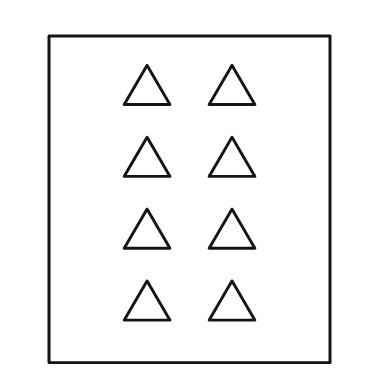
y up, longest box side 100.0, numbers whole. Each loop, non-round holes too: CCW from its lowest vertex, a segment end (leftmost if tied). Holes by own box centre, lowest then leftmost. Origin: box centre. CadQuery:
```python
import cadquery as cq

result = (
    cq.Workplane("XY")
    .moveTo(-43.0, -50.0)
    .lineTo(43.0, -50.0)
    .lineTo(43.0, 50.0)
    .lineTo(-43.0, 50.0)
    .close()
    .moveTo(-20.0, -37.0)
    .lineTo(-6.0, -37.0)
    .lineTo(-13.0, -25.0)
    .close()
    .moveTo(6.0, -37.0)
    .lineTo(20.0, -37.0)
    .lineTo(13.0, -25.0)
    .close()
    .moveTo(-20.0, -15.0)
    .lineTo(-6.0, -15.0)
    .lineTo(-13.0, -3.0)
    .close()
    .moveTo(6.0, -15.0)
    .lineTo(20.0, -15.0)
    .lineTo(13.0, -3.0)
    .close()
    .moveTo(-20.0, 7.0)
    .lineTo(-6.0, 7.0)
    .lineTo(-13.0, 19.0)
    .close()
    .moveTo(6.0, 7.0)
    .lineTo(20.0, 7.0)
    .lineTo(13.0, 19.0)
    .close()
    .moveTo(-20.0, 29.0)
    .lineTo(-6.0, 29.0)
    .lineTo(-13.0, 41.0)
    .close()
    .moveTo(6.0, 29.0)
    .lineTo(20.0, 29.0)
    .lineTo(13.0, 41.0)
    .close()
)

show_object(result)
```